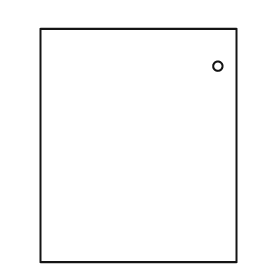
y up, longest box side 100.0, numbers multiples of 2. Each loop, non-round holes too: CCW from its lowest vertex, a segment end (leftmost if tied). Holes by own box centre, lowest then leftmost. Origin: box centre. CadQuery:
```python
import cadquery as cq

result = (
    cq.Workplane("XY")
    .moveTo(-42.0, -50.0)
    .lineTo(42.0, -50.0)
    .lineTo(42.0, 50.0)
    .lineTo(-42.0, 50.0)
    .close()
    .moveTo(34.0, 34.0)
    .circle(2.0)
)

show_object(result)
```